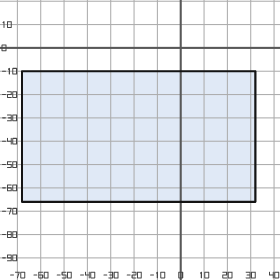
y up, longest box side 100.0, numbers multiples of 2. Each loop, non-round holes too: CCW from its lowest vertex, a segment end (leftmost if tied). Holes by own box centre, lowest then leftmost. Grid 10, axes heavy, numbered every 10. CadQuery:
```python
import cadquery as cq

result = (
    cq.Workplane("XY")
    .moveTo(-68.0, -66.0)
    .lineTo(32.0, -66.0)
    .lineTo(32.0, -10.0)
    .lineTo(-68.0, -10.0)
    .close()
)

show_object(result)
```